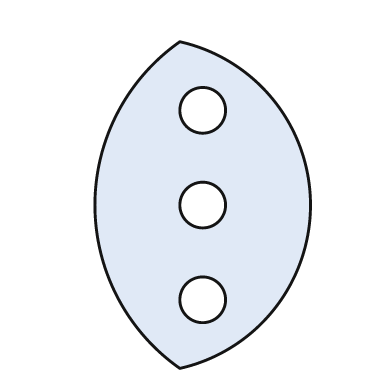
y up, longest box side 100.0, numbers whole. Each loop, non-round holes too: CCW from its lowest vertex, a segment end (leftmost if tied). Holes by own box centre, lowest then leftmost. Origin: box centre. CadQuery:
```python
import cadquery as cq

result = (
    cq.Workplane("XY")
    .moveTo(-7.0, -50.0)
    .threePointArc((33.0, 0.0), (-7.0, 50.0))
    .threePointArc((-33.0, 0.0), (-7.0, -50.0))
    .close()
    .moveTo(0.0, -29.0)
    .circle(7.0)
    .moveTo(0.0, 0.0)
    .circle(7.0)
    .moveTo(0.0, 29.0)
    .circle(7.0)
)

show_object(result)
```